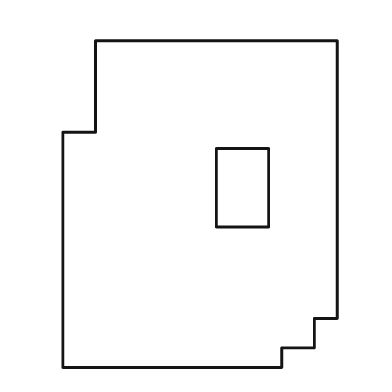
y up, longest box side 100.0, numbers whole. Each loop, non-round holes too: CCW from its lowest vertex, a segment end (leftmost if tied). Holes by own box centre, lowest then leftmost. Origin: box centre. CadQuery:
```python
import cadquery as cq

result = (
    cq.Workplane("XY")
    .moveTo(-42.0, -50.0)
    .lineTo(25.0, -50.0)
    .lineTo(25.0, -44.0)
    .lineTo(35.0, -44.0)
    .lineTo(35.0, -35.0)
    .lineTo(42.0, -35.0)
    .lineTo(42.0, 50.0)
    .lineTo(-32.0, 50.0)
    .lineTo(-32.0, 22.0)
    .lineTo(-42.0, 22.0)
    .close()
    .moveTo(5.0, -7.0)
    .lineTo(21.0, -7.0)
    .lineTo(21.0, 17.0)
    .lineTo(5.0, 17.0)
    .close()
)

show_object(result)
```